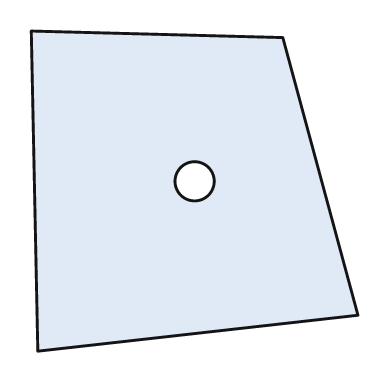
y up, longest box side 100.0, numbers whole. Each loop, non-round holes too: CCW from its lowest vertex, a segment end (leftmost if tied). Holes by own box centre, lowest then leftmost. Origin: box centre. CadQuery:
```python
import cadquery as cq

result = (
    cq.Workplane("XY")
    .moveTo(-48.0, -49.0)
    .lineTo(50.0, -38.0)
    .lineTo(27.0, 47.0)
    .lineTo(-50.0, 49.0)
    .close()
    .moveTo(0.0, 3.0)
    .circle(6.0)
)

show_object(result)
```